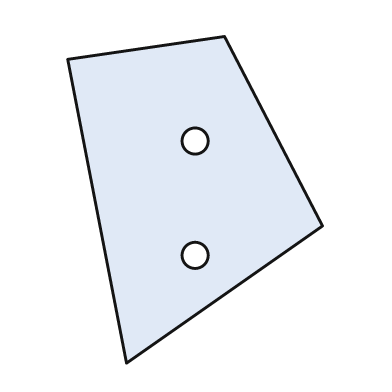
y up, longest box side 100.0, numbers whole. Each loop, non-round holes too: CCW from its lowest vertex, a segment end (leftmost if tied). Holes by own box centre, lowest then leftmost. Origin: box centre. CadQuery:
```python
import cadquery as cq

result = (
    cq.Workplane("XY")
    .moveTo(-21.0, -50.0)
    .lineTo(39.0, -8.0)
    .lineTo(9.0, 50.0)
    .lineTo(-39.0, 43.0)
    .close()
    .moveTo(0.0, -17.0)
    .circle(4.0)
    .moveTo(0.0, 18.0)
    .circle(4.0)
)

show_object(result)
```